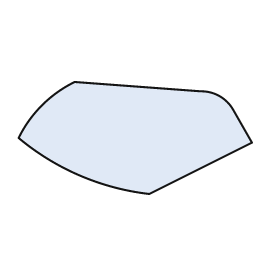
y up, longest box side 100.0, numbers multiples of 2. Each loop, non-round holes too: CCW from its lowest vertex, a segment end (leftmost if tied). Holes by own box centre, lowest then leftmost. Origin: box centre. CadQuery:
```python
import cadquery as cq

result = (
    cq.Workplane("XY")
    .moveTo(6.0, -24.0)
    .lineTo(50.0, -2.0)
    .lineTo(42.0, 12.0)
    .threePointArc((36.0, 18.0), (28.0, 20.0))
    .lineTo(-26.0, 24.0)
    .threePointArc((-40.0, 14.0), (-50.0, 0.0))
    .threePointArc((-24.0, -16.0), (6.0, -24.0))
    .close()
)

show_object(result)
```